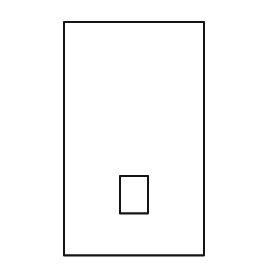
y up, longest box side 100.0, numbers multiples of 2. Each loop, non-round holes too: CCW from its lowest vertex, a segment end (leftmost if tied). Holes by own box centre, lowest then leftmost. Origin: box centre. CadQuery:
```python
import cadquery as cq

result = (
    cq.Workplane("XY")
    .moveTo(-30.0, -50.0)
    .lineTo(30.0, -50.0)
    .lineTo(30.0, 50.0)
    .lineTo(-30.0, 50.0)
    .close()
    .moveTo(-6.0, -32.0)
    .lineTo(6.0, -32.0)
    .lineTo(6.0, -16.0)
    .lineTo(-6.0, -16.0)
    .close()
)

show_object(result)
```